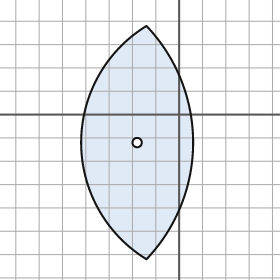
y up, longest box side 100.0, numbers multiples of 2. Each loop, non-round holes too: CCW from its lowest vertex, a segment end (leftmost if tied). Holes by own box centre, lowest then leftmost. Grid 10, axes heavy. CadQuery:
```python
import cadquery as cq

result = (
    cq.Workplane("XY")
    .moveTo(-14.0, -62.0)
    .threePointArc((6.0, -12.0), (-14.0, 38.0))
    .threePointArc((-42.0, -12.0), (-14.0, -62.0))
    .close()
    .moveTo(-18.0, -12.0)
    .circle(2.0)
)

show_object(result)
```